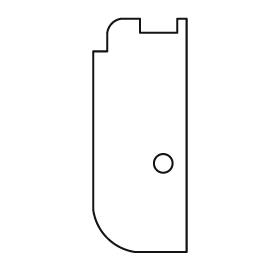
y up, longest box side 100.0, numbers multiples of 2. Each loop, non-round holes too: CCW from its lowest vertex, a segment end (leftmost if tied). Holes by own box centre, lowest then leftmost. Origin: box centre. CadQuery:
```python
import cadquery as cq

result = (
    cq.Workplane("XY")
    .moveTo(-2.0, -50.0)
    .lineTo(20.0, -50.0)
    .lineTo(20.0, 50.0)
    .lineTo(16.0, 50.0)
    .lineTo(16.0, 44.0)
    .lineTo(0.0, 44.0)
    .lineTo(0.0, 50.0)
    .lineTo(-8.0, 50.0)
    .threePointArc((-12.0, 48.0), (-14.0, 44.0))
    .lineTo(-14.0, 36.0)
    .lineTo(-20.0, 36.0)
    .lineTo(-20.0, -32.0)
    .threePointArc((-14.0, -44.0), (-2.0, -50.0))
    .close()
    .moveTo(10.0, -12.0)
    .circle(4.0)
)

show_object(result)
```